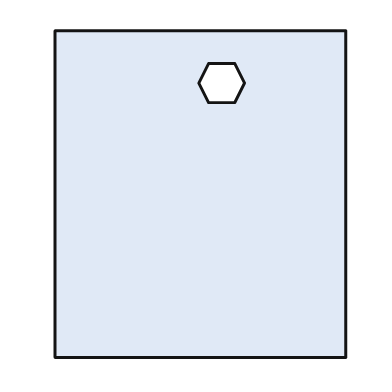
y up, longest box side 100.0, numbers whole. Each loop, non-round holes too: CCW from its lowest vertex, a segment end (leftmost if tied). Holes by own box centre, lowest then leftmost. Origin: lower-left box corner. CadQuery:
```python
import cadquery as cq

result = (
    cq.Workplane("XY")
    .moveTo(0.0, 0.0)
    .lineTo(89.0, 0.0)
    .lineTo(89.0, 100.0)
    .lineTo(0.0, 100.0)
    .close()
    .moveTo(47.0, 78.0)
    .lineTo(55.0, 78.0)
    .lineTo(58.0, 84.0)
    .lineTo(55.0, 90.0)
    .lineTo(47.0, 90.0)
    .lineTo(44.0, 84.0)
    .close()
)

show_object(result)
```